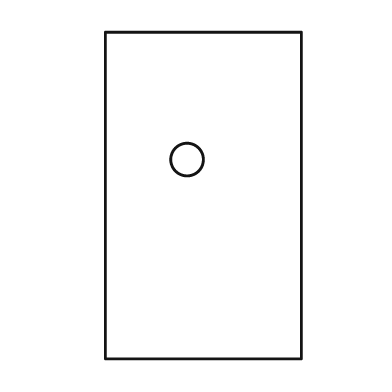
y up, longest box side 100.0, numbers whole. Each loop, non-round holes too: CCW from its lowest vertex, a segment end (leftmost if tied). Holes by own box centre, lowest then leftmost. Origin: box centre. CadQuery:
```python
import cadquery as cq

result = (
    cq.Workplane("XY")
    .moveTo(-30.0, -50.0)
    .lineTo(30.0, -50.0)
    .lineTo(30.0, 50.0)
    .lineTo(-30.0, 50.0)
    .close()
    .moveTo(-5.0, 11.0)
    .circle(5.0)
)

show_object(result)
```